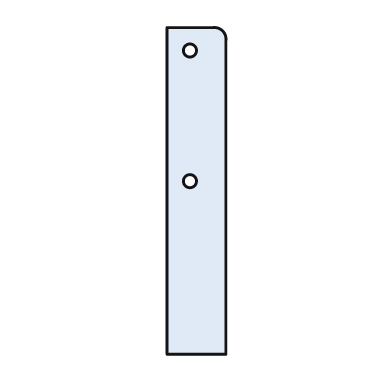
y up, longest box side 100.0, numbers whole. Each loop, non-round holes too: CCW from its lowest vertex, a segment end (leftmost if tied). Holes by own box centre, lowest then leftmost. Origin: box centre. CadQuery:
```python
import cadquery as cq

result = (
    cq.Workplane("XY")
    .moveTo(-9.0, -50.0)
    .lineTo(9.0, -50.0)
    .lineTo(9.0, 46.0)
    .threePointArc((8.0, 49.0), (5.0, 50.0))
    .lineTo(-9.0, 50.0)
    .close()
    .moveTo(-2.0, 3.0)
    .circle(2.0)
    .moveTo(-2.0, 43.0)
    .circle(2.0)
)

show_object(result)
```